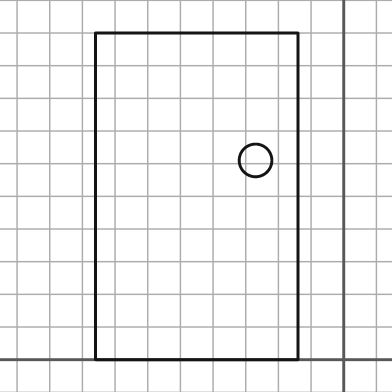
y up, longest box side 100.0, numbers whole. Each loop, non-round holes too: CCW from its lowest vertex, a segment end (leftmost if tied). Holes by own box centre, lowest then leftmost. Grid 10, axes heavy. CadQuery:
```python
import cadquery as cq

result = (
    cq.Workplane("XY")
    .moveTo(-76.0, 0.0)
    .lineTo(-14.0, 0.0)
    .lineTo(-14.0, 100.0)
    .lineTo(-76.0, 100.0)
    .close()
    .moveTo(-27.0, 61.0)
    .circle(5.0)
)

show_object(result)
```